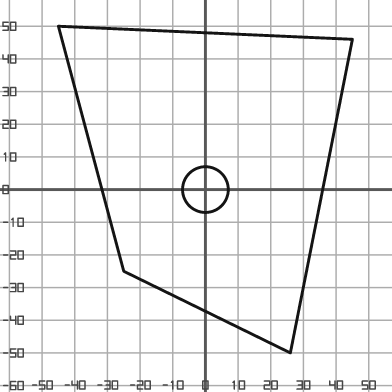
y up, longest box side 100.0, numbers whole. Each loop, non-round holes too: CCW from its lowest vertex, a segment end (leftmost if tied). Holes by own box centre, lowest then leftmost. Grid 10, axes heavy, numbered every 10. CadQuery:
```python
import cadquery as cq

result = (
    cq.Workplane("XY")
    .moveTo(26.0, -50.0)
    .lineTo(45.0, 46.0)
    .lineTo(-45.0, 50.0)
    .lineTo(-25.0, -25.0)
    .close()
    .moveTo(0.0, 0.0)
    .circle(7.0)
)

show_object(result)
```